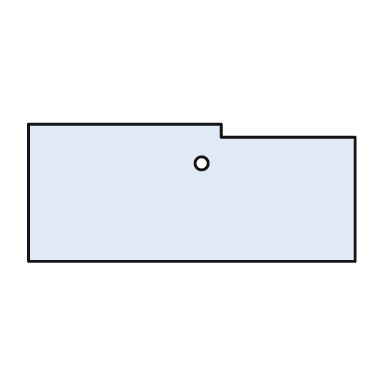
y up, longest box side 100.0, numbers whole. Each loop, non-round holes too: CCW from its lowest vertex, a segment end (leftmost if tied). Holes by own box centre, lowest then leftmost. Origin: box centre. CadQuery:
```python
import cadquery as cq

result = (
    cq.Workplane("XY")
    .moveTo(-50.0, -21.0)
    .lineTo(50.0, -21.0)
    .lineTo(50.0, 17.0)
    .lineTo(9.0, 17.0)
    .lineTo(9.0, 21.0)
    .lineTo(-50.0, 21.0)
    .close()
    .moveTo(3.0, 9.0)
    .circle(2.0)
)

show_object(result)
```